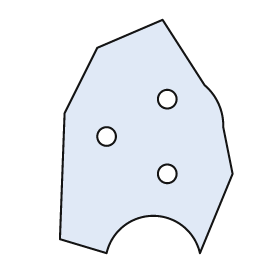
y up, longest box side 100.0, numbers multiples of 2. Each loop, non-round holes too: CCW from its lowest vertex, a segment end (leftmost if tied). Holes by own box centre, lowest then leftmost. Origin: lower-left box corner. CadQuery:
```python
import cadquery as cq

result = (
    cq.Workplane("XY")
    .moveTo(20.0, 0.0)
    .threePointArc((40.0, 16.0), (60.0, 0.0))
    .lineTo(74.0, 34.0)
    .lineTo(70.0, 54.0)
    .threePointArc((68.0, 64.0), (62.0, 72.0))
    .lineTo(44.0, 100.0)
    .lineTo(16.0, 88.0)
    .lineTo(2.0, 60.0)
    .lineTo(0.0, 6.0)
    .close()
    .moveTo(46.0, 34.0)
    .circle(4.0)
    .moveTo(20.0, 50.0)
    .circle(4.0)
    .moveTo(46.0, 66.0)
    .circle(4.0)
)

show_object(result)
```